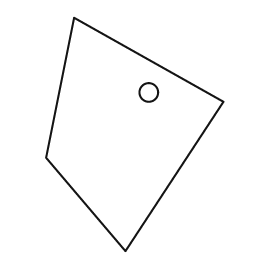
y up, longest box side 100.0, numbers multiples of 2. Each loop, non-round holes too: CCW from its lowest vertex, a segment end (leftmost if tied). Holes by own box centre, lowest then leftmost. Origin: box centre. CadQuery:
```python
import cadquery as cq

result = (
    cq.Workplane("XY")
    .moveTo(-4.0, -50.0)
    .lineTo(38.0, 14.0)
    .lineTo(-26.0, 50.0)
    .lineTo(-38.0, -10.0)
    .close()
    .moveTo(6.0, 18.0)
    .circle(4.0)
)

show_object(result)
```